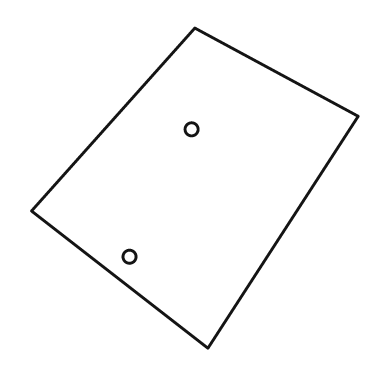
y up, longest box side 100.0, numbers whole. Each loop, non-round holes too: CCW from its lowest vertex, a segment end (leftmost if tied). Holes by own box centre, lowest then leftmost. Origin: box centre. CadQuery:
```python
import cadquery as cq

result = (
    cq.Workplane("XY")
    .moveTo(4.0, -49.0)
    .lineTo(50.0, 22.0)
    .lineTo(0.0, 49.0)
    .lineTo(-50.0, -7.0)
    .close()
    .moveTo(-20.0, -21.0)
    .circle(2.0)
    .moveTo(-1.0, 18.0)
    .circle(2.0)
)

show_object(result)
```